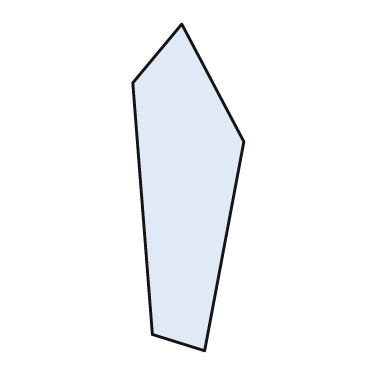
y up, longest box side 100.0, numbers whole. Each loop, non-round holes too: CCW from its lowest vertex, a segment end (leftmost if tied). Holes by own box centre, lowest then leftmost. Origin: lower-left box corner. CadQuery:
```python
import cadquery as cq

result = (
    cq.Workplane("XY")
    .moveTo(22.0, 0.0)
    .lineTo(34.0, 64.0)
    .lineTo(15.0, 100.0)
    .lineTo(0.0, 82.0)
    .lineTo(6.0, 5.0)
    .close()
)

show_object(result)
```